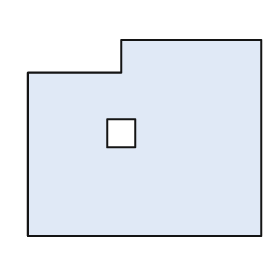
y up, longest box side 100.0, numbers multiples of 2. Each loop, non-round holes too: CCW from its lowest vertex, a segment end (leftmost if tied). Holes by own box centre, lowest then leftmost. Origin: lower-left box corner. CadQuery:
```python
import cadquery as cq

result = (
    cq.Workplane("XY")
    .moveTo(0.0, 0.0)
    .lineTo(100.0, 0.0)
    .lineTo(100.0, 84.0)
    .lineTo(40.0, 84.0)
    .lineTo(40.0, 70.0)
    .lineTo(0.0, 70.0)
    .close()
    .moveTo(34.0, 38.0)
    .lineTo(46.0, 38.0)
    .lineTo(46.0, 50.0)
    .lineTo(34.0, 50.0)
    .close()
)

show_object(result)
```